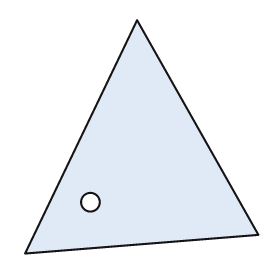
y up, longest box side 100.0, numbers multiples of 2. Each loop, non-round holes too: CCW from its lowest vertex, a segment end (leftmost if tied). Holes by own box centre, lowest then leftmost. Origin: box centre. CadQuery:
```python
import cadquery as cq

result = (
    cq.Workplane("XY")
    .moveTo(-50.0, -50.0)
    .lineTo(50.0, -42.0)
    .lineTo(-2.0, 50.0)
    .close()
    .moveTo(-22.0, -28.0)
    .circle(4.0)
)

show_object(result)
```